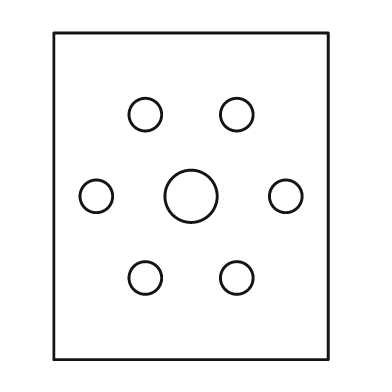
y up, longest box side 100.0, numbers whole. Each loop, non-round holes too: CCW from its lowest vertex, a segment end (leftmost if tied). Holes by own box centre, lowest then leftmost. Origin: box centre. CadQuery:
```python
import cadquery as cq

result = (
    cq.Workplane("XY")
    .moveTo(-42.0, -50.0)
    .lineTo(42.0, -50.0)
    .lineTo(42.0, 50.0)
    .lineTo(-42.0, 50.0)
    .close()
    .moveTo(-14.0, -25.0)
    .circle(5.0)
    .moveTo(14.0, -25.0)
    .circle(5.0)
    .moveTo(-29.0, 0.0)
    .circle(5.0)
    .moveTo(0.0, 0.0)
    .circle(8.0)
    .moveTo(29.0, 0.0)
    .circle(5.0)
    .moveTo(-14.0, 25.0)
    .circle(5.0)
    .moveTo(14.0, 25.0)
    .circle(5.0)
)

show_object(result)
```